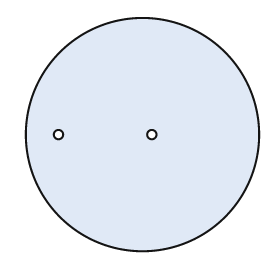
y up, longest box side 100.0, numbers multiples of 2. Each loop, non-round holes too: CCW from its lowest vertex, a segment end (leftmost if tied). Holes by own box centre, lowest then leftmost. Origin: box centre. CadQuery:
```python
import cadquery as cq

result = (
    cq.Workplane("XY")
    .moveTo(0.0, 0.0)
    .circle(50.0)
    .moveTo(-36.0, 0.0)
    .circle(2.0)
    .moveTo(4.0, 0.0)
    .circle(2.0)
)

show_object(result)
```